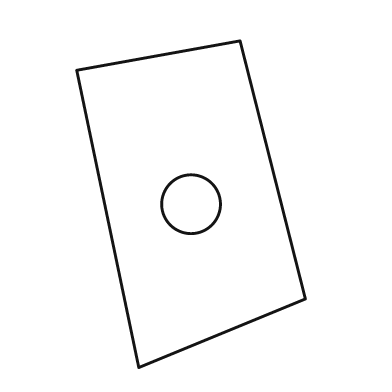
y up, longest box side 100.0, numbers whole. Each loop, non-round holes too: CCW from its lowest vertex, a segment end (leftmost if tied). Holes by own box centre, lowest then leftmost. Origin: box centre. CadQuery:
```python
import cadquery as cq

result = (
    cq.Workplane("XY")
    .moveTo(-16.0, -50.0)
    .lineTo(35.0, -29.0)
    .lineTo(15.0, 50.0)
    .lineTo(-35.0, 41.0)
    .close()
    .moveTo(0.0, 0.0)
    .circle(9.0)
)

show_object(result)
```